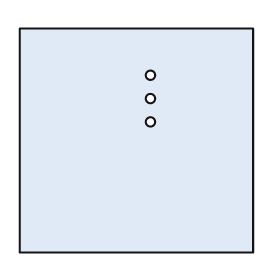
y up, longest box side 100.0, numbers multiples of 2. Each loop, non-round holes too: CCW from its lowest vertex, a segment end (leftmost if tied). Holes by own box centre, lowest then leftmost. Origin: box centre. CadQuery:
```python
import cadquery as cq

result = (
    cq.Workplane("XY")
    .moveTo(-50.0, -48.0)
    .lineTo(50.0, -48.0)
    .lineTo(50.0, 48.0)
    .lineTo(-50.0, 48.0)
    .close()
    .moveTo(6.0, 8.0)
    .circle(2.0)
    .moveTo(6.0, 18.0)
    .circle(2.0)
    .moveTo(6.0, 28.0)
    .circle(2.0)
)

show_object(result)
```